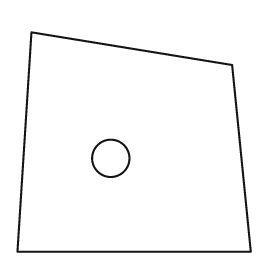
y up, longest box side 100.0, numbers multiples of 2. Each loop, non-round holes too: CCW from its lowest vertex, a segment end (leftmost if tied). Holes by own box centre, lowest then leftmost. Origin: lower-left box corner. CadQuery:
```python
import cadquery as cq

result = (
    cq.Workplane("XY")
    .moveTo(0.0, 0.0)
    .lineTo(100.0, 0.0)
    .lineTo(92.0, 80.0)
    .lineTo(6.0, 94.0)
    .close()
    .moveTo(40.0, 40.0)
    .circle(8.0)
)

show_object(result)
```